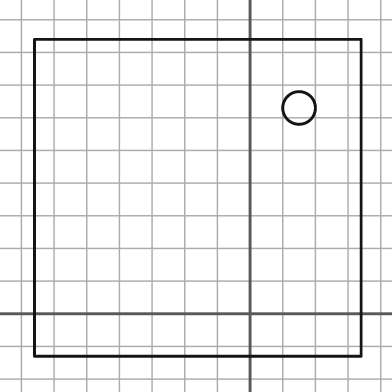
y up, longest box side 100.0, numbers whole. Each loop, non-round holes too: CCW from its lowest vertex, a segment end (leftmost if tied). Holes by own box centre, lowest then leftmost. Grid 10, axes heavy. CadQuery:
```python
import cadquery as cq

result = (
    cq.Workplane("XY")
    .moveTo(-66.0, -13.0)
    .lineTo(34.0, -13.0)
    .lineTo(34.0, 84.0)
    .lineTo(-66.0, 84.0)
    .close()
    .moveTo(15.0, 63.0)
    .circle(5.0)
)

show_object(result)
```